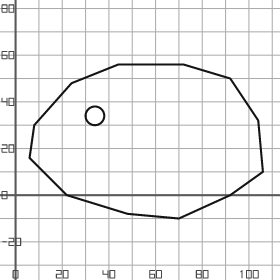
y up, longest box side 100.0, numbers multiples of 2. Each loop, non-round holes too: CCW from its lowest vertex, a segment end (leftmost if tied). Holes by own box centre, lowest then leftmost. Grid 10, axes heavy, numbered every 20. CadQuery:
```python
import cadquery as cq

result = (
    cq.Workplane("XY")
    .moveTo(70.0, -10.0)
    .lineTo(92.0, 0.0)
    .lineTo(106.0, 10.0)
    .lineTo(104.0, 32.0)
    .lineTo(92.0, 50.0)
    .lineTo(72.0, 56.0)
    .lineTo(44.0, 56.0)
    .lineTo(24.0, 48.0)
    .lineTo(8.0, 30.0)
    .lineTo(6.0, 16.0)
    .lineTo(22.0, 0.0)
    .lineTo(48.0, -8.0)
    .close()
    .moveTo(34.0, 34.0)
    .circle(4.0)
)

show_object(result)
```